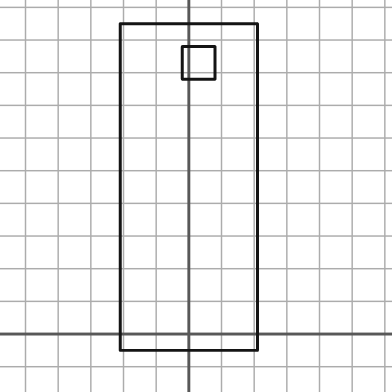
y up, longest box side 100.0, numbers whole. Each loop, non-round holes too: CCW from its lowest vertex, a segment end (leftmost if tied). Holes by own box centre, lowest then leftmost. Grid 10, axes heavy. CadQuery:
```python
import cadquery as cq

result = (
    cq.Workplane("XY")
    .moveTo(-21.0, -5.0)
    .lineTo(21.0, -5.0)
    .lineTo(21.0, 95.0)
    .lineTo(-21.0, 95.0)
    .close()
    .moveTo(-2.0, 78.0)
    .lineTo(8.0, 78.0)
    .lineTo(8.0, 88.0)
    .lineTo(-2.0, 88.0)
    .close()
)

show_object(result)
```